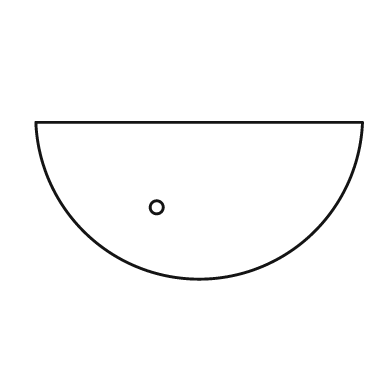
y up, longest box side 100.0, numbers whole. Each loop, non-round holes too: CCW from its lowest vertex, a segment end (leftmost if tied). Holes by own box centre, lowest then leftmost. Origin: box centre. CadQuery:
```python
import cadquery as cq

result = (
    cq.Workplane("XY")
    .moveTo(-50.0, 24.0)
    .threePointArc((0.0, -24.0), (50.0, 24.0))
    .close()
    .moveTo(-13.0, -2.0)
    .circle(2.0)
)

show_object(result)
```